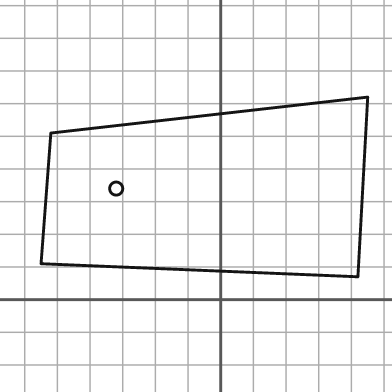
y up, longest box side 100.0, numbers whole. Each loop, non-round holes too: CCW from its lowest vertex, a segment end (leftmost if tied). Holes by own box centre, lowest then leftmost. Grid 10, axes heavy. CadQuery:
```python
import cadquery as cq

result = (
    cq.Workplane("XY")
    .moveTo(42.0, 7.0)
    .lineTo(45.0, 62.0)
    .lineTo(-52.0, 51.0)
    .lineTo(-55.0, 11.0)
    .close()
    .moveTo(-32.0, 34.0)
    .circle(2.0)
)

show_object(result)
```